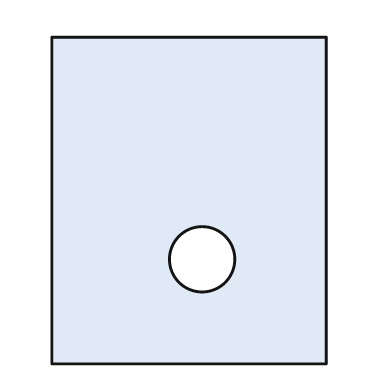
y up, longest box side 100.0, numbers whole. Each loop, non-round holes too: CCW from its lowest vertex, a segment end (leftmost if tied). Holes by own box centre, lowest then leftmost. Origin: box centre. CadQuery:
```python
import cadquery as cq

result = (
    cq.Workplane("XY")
    .moveTo(-42.0, -50.0)
    .lineTo(42.0, -50.0)
    .lineTo(42.0, 50.0)
    .lineTo(-42.0, 50.0)
    .close()
    .moveTo(4.0, -18.0)
    .circle(10.0)
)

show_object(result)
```